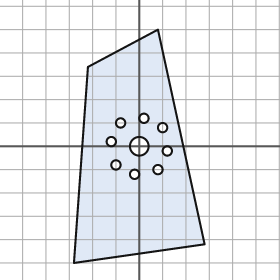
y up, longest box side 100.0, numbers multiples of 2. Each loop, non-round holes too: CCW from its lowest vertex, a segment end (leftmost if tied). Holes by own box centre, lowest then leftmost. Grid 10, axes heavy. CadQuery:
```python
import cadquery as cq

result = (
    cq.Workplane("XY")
    .moveTo(-28.0, -50.0)
    .lineTo(28.0, -42.0)
    .lineTo(8.0, 50.0)
    .lineTo(-22.0, 34.0)
    .close()
    .moveTo(-2.0, -12.0)
    .circle(2.0)
    .moveTo(8.0, -10.0)
    .circle(2.0)
    .moveTo(-10.0, -8.0)
    .circle(2.0)
    .moveTo(12.0, -2.0)
    .circle(2.0)
    .moveTo(0.0, 0.0)
    .circle(4.0)
    .moveTo(-12.0, 2.0)
    .circle(2.0)
    .moveTo(10.0, 8.0)
    .circle(2.0)
    .moveTo(-8.0, 10.0)
    .circle(2.0)
    .moveTo(2.0, 12.0)
    .circle(2.0)
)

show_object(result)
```